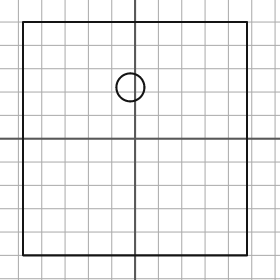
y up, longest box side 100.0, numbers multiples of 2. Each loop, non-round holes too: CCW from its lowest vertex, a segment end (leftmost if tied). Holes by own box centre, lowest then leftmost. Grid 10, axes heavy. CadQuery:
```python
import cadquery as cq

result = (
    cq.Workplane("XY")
    .moveTo(-48.0, -50.0)
    .lineTo(48.0, -50.0)
    .lineTo(48.0, 50.0)
    .lineTo(-48.0, 50.0)
    .close()
    .moveTo(-2.0, 22.0)
    .circle(6.0)
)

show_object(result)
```